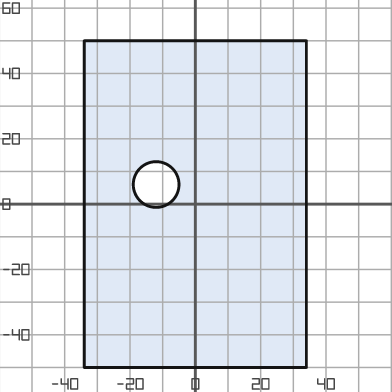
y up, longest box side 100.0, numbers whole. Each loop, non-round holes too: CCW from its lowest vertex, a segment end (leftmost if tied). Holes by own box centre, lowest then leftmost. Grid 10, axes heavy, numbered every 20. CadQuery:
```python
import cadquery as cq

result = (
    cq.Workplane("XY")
    .moveTo(-34.0, -50.0)
    .lineTo(34.0, -50.0)
    .lineTo(34.0, 50.0)
    .lineTo(-34.0, 50.0)
    .close()
    .moveTo(-12.0, 6.0)
    .circle(7.0)
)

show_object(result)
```